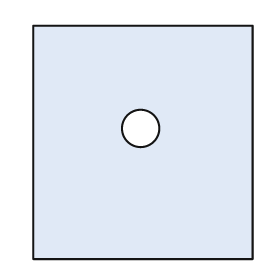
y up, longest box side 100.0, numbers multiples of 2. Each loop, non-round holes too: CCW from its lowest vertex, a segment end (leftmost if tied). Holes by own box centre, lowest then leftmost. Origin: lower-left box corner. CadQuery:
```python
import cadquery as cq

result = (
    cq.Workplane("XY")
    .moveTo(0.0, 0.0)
    .lineTo(94.0, 0.0)
    .lineTo(94.0, 100.0)
    .lineTo(0.0, 100.0)
    .close()
    .moveTo(46.0, 56.0)
    .circle(8.0)
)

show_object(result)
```